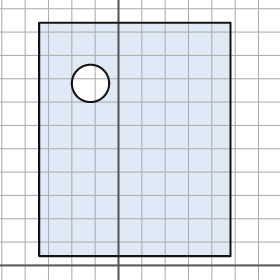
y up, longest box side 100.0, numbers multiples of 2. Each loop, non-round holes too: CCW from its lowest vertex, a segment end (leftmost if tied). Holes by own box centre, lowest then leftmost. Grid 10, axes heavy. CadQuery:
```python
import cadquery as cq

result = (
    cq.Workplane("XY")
    .moveTo(-34.0, 4.0)
    .lineTo(48.0, 4.0)
    .lineTo(48.0, 104.0)
    .lineTo(-34.0, 104.0)
    .close()
    .moveTo(-12.0, 78.0)
    .circle(8.0)
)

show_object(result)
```